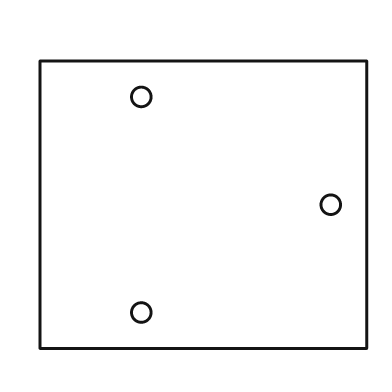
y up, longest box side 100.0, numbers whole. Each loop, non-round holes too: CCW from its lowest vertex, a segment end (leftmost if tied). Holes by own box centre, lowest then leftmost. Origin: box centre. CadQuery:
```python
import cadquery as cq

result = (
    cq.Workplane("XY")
    .moveTo(-50.0, -44.0)
    .lineTo(50.0, -44.0)
    .lineTo(50.0, 44.0)
    .lineTo(-50.0, 44.0)
    .close()
    .moveTo(-19.0, -33.0)
    .circle(3.0)
    .moveTo(39.0, 0.0)
    .circle(3.0)
    .moveTo(-19.0, 33.0)
    .circle(3.0)
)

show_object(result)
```